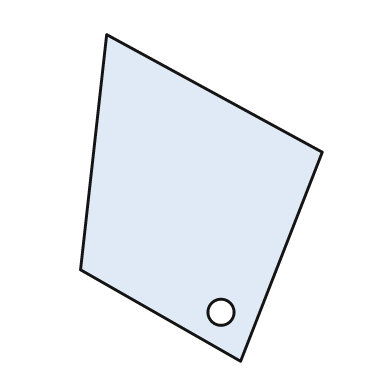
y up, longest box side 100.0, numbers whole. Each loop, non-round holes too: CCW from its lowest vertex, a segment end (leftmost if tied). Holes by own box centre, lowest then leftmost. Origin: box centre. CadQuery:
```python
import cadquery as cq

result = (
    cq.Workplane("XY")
    .moveTo(12.0, -50.0)
    .lineTo(37.0, 14.0)
    .lineTo(-29.0, 50.0)
    .lineTo(-37.0, -22.0)
    .close()
    .moveTo(6.0, -35.0)
    .circle(4.0)
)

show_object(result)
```